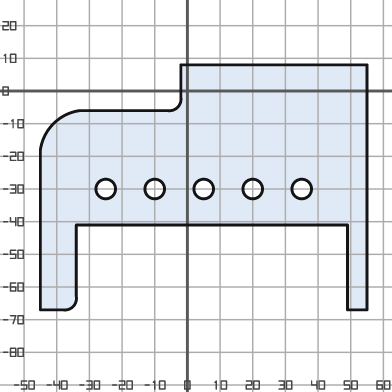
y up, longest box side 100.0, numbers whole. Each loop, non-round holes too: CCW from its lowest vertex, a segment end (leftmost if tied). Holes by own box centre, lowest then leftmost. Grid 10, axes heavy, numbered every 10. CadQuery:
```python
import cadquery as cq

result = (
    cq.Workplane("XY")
    .moveTo(-45.0, -67.0)
    .lineTo(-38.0, -67.0)
    .threePointArc((-35.0, -66.0), (-34.0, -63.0))
    .lineTo(-34.0, -41.0)
    .lineTo(49.0, -41.0)
    .lineTo(49.0, -67.0)
    .lineTo(55.0, -67.0)
    .lineTo(55.0, 8.0)
    .lineTo(-2.0, 8.0)
    .lineTo(-2.0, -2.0)
    .threePointArc((-3.0, -5.0), (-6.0, -6.0))
    .lineTo(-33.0, -6.0)
    .threePointArc((-41.0, -10.0), (-45.0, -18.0))
    .close()
    .moveTo(-25.0, -30.0)
    .circle(3.0)
    .moveTo(-10.0, -30.0)
    .circle(3.0)
    .moveTo(5.0, -30.0)
    .circle(3.0)
    .moveTo(20.0, -30.0)
    .circle(3.0)
    .moveTo(35.0, -30.0)
    .circle(3.0)
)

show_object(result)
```